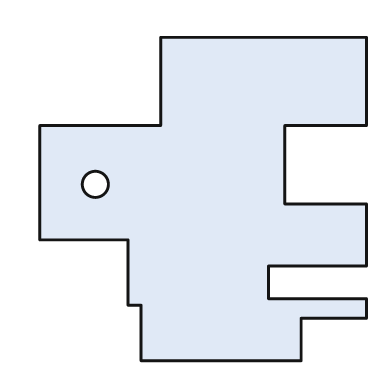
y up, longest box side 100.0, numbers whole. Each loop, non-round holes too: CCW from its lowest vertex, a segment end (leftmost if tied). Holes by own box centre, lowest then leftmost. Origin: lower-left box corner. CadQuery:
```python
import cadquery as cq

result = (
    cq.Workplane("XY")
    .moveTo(31.0, 0.0)
    .lineTo(80.0, 0.0)
    .lineTo(80.0, 13.0)
    .lineTo(100.0, 13.0)
    .lineTo(100.0, 19.0)
    .lineTo(70.0, 19.0)
    .lineTo(70.0, 29.0)
    .lineTo(100.0, 29.0)
    .lineTo(100.0, 48.0)
    .lineTo(75.0, 48.0)
    .lineTo(75.0, 72.0)
    .lineTo(100.0, 72.0)
    .lineTo(100.0, 99.0)
    .lineTo(37.0, 99.0)
    .lineTo(37.0, 72.0)
    .lineTo(0.0, 72.0)
    .lineTo(0.0, 37.0)
    .lineTo(27.0, 37.0)
    .lineTo(27.0, 17.0)
    .lineTo(31.0, 17.0)
    .close()
    .moveTo(17.0, 54.0)
    .circle(4.0)
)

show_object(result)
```